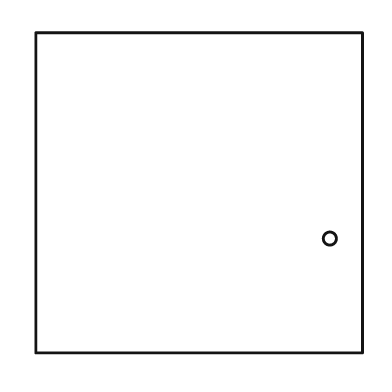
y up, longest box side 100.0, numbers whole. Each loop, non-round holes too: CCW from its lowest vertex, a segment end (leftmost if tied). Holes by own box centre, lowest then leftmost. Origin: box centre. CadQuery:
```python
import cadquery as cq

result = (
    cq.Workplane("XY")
    .moveTo(-50.0, -49.0)
    .lineTo(50.0, -49.0)
    .lineTo(50.0, 49.0)
    .lineTo(-50.0, 49.0)
    .close()
    .moveTo(40.0, -14.0)
    .circle(2.0)
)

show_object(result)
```